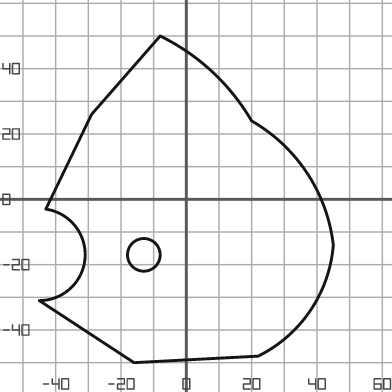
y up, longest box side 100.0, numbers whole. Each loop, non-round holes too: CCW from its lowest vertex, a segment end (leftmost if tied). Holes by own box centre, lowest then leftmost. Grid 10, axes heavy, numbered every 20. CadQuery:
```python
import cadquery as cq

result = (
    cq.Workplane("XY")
    .moveTo(-16.0, -50.0)
    .lineTo(22.0, -48.0)
    .threePointArc((38.0, -34.0), (45.0, -14.0))
    .threePointArc((37.0, 8.0), (20.0, 24.0))
    .threePointArc((8.0, 39.0), (-8.0, 50.0))
    .lineTo(-29.0, 26.0)
    .lineTo(-43.0, -3.0)
    .threePointArc((-31.0, -18.0), (-45.0, -31.0))
    .close()
    .moveTo(-13.0, -17.0)
    .circle(5.0)
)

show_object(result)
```